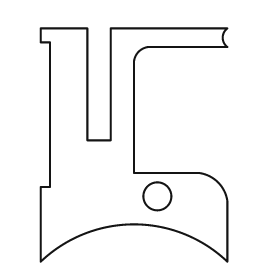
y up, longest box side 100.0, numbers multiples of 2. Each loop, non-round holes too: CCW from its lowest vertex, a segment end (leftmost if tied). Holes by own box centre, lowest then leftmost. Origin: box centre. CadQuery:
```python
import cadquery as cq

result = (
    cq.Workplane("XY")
    .moveTo(-40.0, -50.0)
    .threePointArc((0.0, -34.0), (40.0, -50.0))
    .lineTo(40.0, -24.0)
    .threePointArc((36.0, -16.0), (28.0, -12.0))
    .lineTo(0.0, -12.0)
    .lineTo(0.0, 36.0)
    .threePointArc((2.0, 40.0), (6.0, 42.0))
    .lineTo(40.0, 42.0)
    .threePointArc((38.0, 46.0), (40.0, 50.0))
    .lineTo(-10.0, 50.0)
    .lineTo(-10.0, 2.0)
    .lineTo(-20.0, 2.0)
    .lineTo(-20.0, 50.0)
    .lineTo(-40.0, 50.0)
    .lineTo(-40.0, 44.0)
    .lineTo(-36.0, 44.0)
    .lineTo(-36.0, -18.0)
    .lineTo(-40.0, -18.0)
    .close()
    .moveTo(10.0, -22.0)
    .circle(6.0)
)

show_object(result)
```